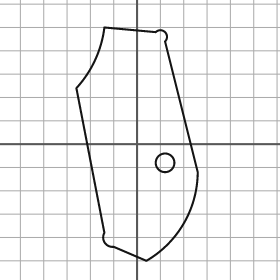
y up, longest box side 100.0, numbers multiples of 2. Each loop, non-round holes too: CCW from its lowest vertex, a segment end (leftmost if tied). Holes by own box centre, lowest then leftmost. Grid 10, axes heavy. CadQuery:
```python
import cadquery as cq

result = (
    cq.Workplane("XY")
    .moveTo(4.0, -50.0)
    .threePointArc((20.0, -34.0), (26.0, -12.0))
    .lineTo(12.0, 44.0)
    .threePointArc((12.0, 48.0), (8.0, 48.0))
    .lineTo(-14.0, 50.0)
    .threePointArc((-18.0, 36.0), (-26.0, 24.0))
    .lineTo(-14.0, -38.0)
    .threePointArc((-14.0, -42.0), (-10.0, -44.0))
    .close()
    .moveTo(12.0, -8.0)
    .circle(4.0)
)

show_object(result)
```